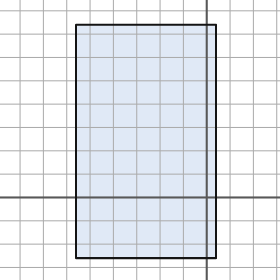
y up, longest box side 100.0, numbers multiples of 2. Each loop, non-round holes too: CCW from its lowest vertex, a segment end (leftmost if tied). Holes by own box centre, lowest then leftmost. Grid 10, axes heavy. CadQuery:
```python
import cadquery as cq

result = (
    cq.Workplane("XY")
    .moveTo(-56.0, -26.0)
    .lineTo(4.0, -26.0)
    .lineTo(4.0, 74.0)
    .lineTo(-56.0, 74.0)
    .close()
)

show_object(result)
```